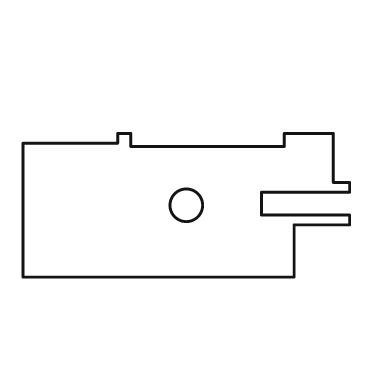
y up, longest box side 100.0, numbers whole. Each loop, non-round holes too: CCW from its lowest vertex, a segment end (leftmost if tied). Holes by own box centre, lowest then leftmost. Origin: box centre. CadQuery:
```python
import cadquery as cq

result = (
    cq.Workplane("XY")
    .moveTo(-50.0, -22.0)
    .lineTo(33.0, -22.0)
    .lineTo(33.0, -6.0)
    .lineTo(50.0, -6.0)
    .lineTo(50.0, -3.0)
    .lineTo(23.0, -3.0)
    .lineTo(23.0, 4.0)
    .lineTo(50.0, 4.0)
    .lineTo(50.0, 7.0)
    .lineTo(45.0, 7.0)
    .lineTo(45.0, 22.0)
    .lineTo(30.0, 22.0)
    .lineTo(30.0, 18.0)
    .lineTo(-17.0, 18.0)
    .lineTo(-17.0, 22.0)
    .lineTo(-21.0, 22.0)
    .lineTo(-21.0, 19.0)
    .lineTo(-50.0, 19.0)
    .close()
    .moveTo(0.0, 0.0)
    .circle(5.0)
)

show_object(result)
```